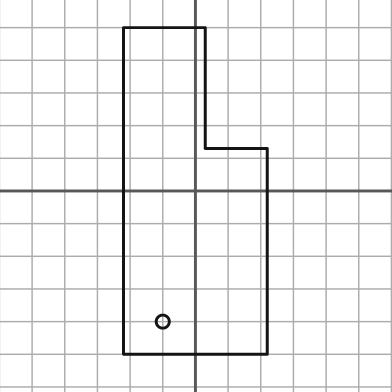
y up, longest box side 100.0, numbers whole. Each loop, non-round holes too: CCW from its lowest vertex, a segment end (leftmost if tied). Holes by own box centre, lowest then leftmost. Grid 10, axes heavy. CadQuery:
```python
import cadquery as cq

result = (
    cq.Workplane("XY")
    .moveTo(-22.0, -50.0)
    .lineTo(22.0, -50.0)
    .lineTo(22.0, 13.0)
    .lineTo(3.0, 13.0)
    .lineTo(3.0, 50.0)
    .lineTo(-22.0, 50.0)
    .close()
    .moveTo(-10.0, -40.0)
    .circle(2.0)
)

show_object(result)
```